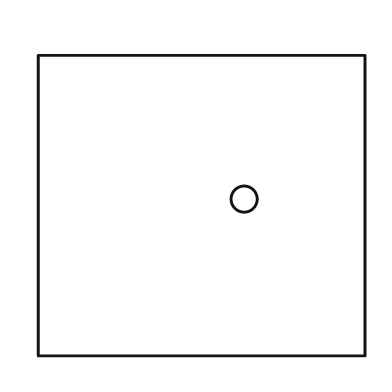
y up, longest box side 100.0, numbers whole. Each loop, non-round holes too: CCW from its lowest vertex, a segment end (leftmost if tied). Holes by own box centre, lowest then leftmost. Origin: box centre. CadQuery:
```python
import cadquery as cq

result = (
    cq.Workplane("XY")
    .moveTo(-50.0, -46.0)
    .lineTo(50.0, -46.0)
    .lineTo(50.0, 46.0)
    .lineTo(-50.0, 46.0)
    .close()
    .moveTo(13.0, 2.0)
    .circle(4.0)
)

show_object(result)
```